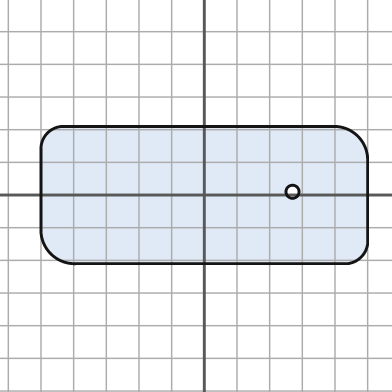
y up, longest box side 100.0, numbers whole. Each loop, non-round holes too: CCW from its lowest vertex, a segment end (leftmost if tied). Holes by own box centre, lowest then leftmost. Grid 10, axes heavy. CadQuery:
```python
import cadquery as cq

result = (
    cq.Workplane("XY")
    .moveTo(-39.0, -21.0)
    .lineTo(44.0, -21.0)
    .threePointArc((48.0, -19.0), (50.0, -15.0))
    .lineTo(50.0, 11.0)
    .threePointArc((47.0, 18.0), (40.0, 21.0))
    .lineTo(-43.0, 21.0)
    .threePointArc((-48.0, 19.0), (-50.0, 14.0))
    .lineTo(-50.0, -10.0)
    .threePointArc((-47.0, -18.0), (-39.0, -21.0))
    .close()
    .moveTo(27.0, 1.0)
    .circle(2.0)
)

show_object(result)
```